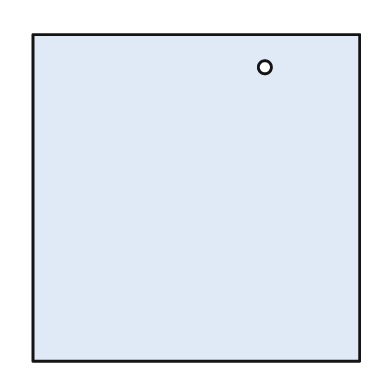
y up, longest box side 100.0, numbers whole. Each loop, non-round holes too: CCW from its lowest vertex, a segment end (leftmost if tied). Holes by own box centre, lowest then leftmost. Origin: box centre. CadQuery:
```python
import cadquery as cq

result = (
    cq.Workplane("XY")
    .moveTo(-50.0, -50.0)
    .lineTo(50.0, -50.0)
    .lineTo(50.0, 50.0)
    .lineTo(-50.0, 50.0)
    .close()
    .moveTo(21.0, 40.0)
    .circle(2.0)
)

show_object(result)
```